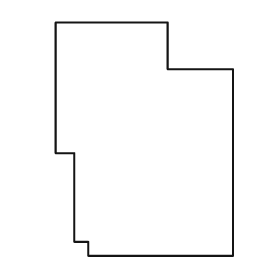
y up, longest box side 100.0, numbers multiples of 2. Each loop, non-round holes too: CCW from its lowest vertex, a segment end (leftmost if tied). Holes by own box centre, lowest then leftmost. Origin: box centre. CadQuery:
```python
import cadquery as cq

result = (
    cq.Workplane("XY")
    .moveTo(-24.0, -50.0)
    .lineTo(38.0, -50.0)
    .lineTo(38.0, 30.0)
    .lineTo(10.0, 30.0)
    .lineTo(10.0, 50.0)
    .lineTo(-38.0, 50.0)
    .lineTo(-38.0, -6.0)
    .lineTo(-30.0, -6.0)
    .lineTo(-30.0, -44.0)
    .lineTo(-24.0, -44.0)
    .close()
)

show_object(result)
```